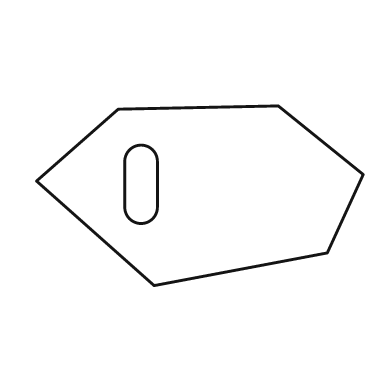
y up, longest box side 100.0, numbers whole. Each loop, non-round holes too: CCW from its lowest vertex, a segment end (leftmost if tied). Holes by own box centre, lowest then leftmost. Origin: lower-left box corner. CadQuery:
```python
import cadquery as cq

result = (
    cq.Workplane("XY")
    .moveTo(36.0, 0.0)
    .lineTo(89.0, 10.0)
    .lineTo(100.0, 34.0)
    .lineTo(74.0, 55.0)
    .lineTo(25.0, 54.0)
    .lineTo(0.0, 32.0)
    .close()
    .moveTo(27.0, 24.0)
    .threePointArc((32.0, 19.0), (37.0, 24.0))
    .lineTo(37.0, 38.0)
    .threePointArc((32.0, 43.0), (27.0, 38.0))
    .close()
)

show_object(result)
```